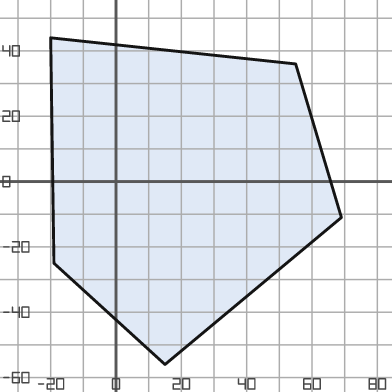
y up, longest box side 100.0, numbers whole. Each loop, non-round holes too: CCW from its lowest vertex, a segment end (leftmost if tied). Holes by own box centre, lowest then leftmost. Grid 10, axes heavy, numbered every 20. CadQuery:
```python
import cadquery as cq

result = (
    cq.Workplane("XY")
    .moveTo(15.0, -56.0)
    .lineTo(69.0, -11.0)
    .lineTo(55.0, 36.0)
    .lineTo(-20.0, 44.0)
    .lineTo(-19.0, -25.0)
    .close()
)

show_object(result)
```